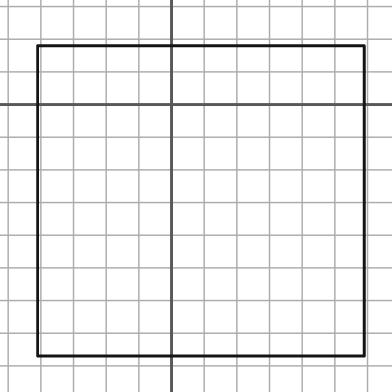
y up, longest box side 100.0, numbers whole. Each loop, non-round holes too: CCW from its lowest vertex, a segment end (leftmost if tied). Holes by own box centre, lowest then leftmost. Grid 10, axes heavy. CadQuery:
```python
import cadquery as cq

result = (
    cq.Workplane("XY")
    .moveTo(-41.0, -77.0)
    .lineTo(59.0, -77.0)
    .lineTo(59.0, 18.0)
    .lineTo(-41.0, 18.0)
    .close()
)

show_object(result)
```